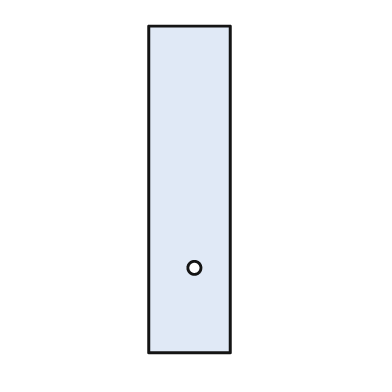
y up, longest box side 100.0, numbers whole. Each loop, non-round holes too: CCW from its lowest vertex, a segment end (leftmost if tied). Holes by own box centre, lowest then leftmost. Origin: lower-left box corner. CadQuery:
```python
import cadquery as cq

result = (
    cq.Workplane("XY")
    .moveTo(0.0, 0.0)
    .lineTo(25.0, 0.0)
    .lineTo(25.0, 100.0)
    .lineTo(0.0, 100.0)
    .close()
    .moveTo(14.0, 26.0)
    .circle(2.0)
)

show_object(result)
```